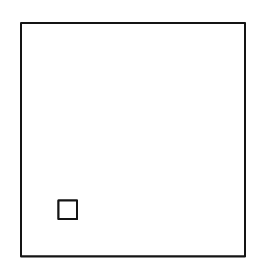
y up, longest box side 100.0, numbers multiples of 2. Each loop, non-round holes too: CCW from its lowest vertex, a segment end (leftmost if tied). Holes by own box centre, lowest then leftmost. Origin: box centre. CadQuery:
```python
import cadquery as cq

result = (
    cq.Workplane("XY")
    .moveTo(-48.0, -50.0)
    .lineTo(48.0, -50.0)
    .lineTo(48.0, 50.0)
    .lineTo(-48.0, 50.0)
    .close()
    .moveTo(-32.0, -34.0)
    .lineTo(-24.0, -34.0)
    .lineTo(-24.0, -26.0)
    .lineTo(-32.0, -26.0)
    .close()
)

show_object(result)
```